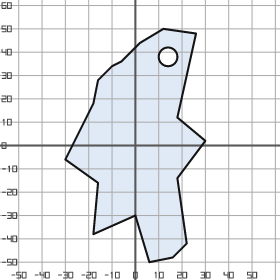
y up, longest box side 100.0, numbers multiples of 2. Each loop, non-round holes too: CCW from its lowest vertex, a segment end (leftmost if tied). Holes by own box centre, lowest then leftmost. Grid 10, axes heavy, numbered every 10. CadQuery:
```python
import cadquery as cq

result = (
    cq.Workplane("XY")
    .moveTo(6.0, -50.0)
    .lineTo(16.0, -48.0)
    .lineTo(22.0, -42.0)
    .lineTo(18.0, -14.0)
    .lineTo(30.0, 2.0)
    .lineTo(18.0, 12.0)
    .lineTo(26.0, 48.0)
    .lineTo(12.0, 50.0)
    .lineTo(2.0, 44.0)
    .lineTo(-6.0, 36.0)
    .lineTo(-10.0, 34.0)
    .lineTo(-16.0, 28.0)
    .lineTo(-18.0, 18.0)
    .lineTo(-30.0, -6.0)
    .lineTo(-16.0, -16.0)
    .lineTo(-18.0, -38.0)
    .lineTo(0.0, -30.0)
    .close()
    .moveTo(14.0, 38.0)
    .circle(4.0)
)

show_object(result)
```